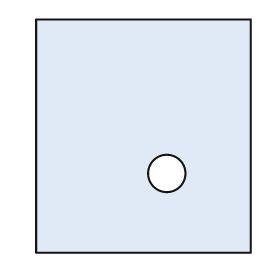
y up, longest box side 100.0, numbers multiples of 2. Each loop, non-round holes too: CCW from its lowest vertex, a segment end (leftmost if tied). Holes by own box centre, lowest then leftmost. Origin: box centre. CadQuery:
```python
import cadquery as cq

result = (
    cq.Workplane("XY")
    .moveTo(-46.0, -50.0)
    .lineTo(46.0, -50.0)
    .lineTo(46.0, 50.0)
    .lineTo(-46.0, 50.0)
    .close()
    .moveTo(10.0, -16.0)
    .circle(8.0)
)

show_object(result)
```